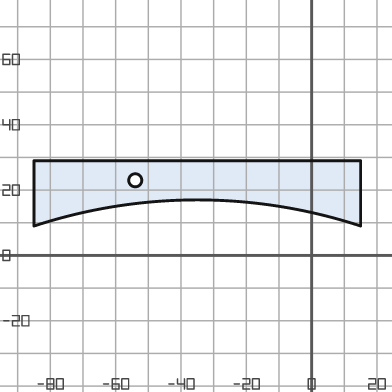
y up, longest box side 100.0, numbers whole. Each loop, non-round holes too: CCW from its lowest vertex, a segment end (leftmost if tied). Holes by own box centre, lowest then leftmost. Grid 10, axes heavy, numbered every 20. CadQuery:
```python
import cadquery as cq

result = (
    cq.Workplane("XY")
    .moveTo(-85.0, 9.0)
    .threePointArc((-35.0, 17.0), (15.0, 9.0))
    .lineTo(15.0, 29.0)
    .lineTo(-85.0, 29.0)
    .close()
    .moveTo(-54.0, 23.0)
    .circle(2.0)
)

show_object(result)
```